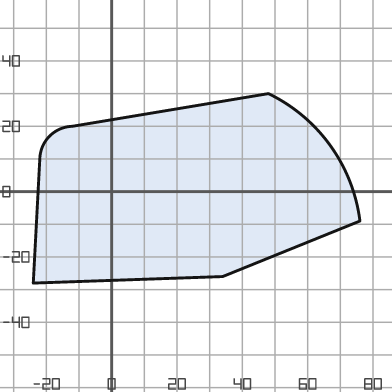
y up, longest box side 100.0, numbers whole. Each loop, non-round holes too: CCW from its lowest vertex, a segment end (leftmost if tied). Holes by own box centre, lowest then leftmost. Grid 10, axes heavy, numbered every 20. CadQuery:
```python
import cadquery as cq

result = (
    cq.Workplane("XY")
    .moveTo(-24.0, -28.0)
    .lineTo(34.0, -26.0)
    .lineTo(76.0, -9.0)
    .threePointArc((67.0, 14.0), (48.0, 30.0))
    .lineTo(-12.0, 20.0)
    .threePointArc((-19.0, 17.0), (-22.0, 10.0))
    .close()
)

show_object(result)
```